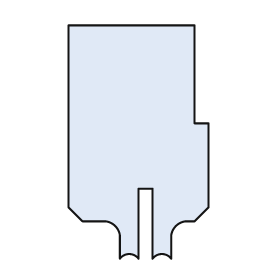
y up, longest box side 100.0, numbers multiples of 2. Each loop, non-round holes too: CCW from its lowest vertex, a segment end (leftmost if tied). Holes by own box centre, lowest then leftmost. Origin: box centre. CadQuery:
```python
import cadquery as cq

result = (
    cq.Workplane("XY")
    .moveTo(-8.0, -50.0)
    .threePointArc((-4.0, -48.0), (0.0, -50.0))
    .lineTo(0.0, -20.0)
    .lineTo(6.0, -20.0)
    .lineTo(6.0, -50.0)
    .threePointArc((10.0, -48.0), (14.0, -50.0))
    .lineTo(14.0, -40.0)
    .threePointArc((16.0, -36.0), (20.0, -34.0))
    .lineTo(24.0, -34.0)
    .lineTo(30.0, -28.0)
    .lineTo(30.0, 8.0)
    .lineTo(24.0, 8.0)
    .lineTo(24.0, 50.0)
    .lineTo(-30.0, 50.0)
    .lineTo(-30.0, -28.0)
    .lineTo(-24.0, -34.0)
    .lineTo(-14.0, -34.0)
    .threePointArc((-10.0, -36.0), (-8.0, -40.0))
    .close()
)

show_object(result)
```